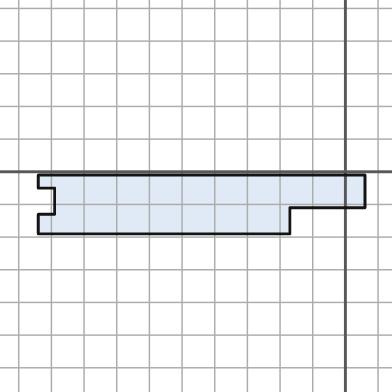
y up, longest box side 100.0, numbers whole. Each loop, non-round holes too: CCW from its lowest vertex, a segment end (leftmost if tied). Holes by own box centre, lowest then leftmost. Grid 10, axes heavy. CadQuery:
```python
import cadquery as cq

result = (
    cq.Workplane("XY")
    .moveTo(-94.0, -19.0)
    .lineTo(-17.0, -19.0)
    .lineTo(-17.0, -11.0)
    .lineTo(6.0, -11.0)
    .lineTo(6.0, -1.0)
    .lineTo(-94.0, -1.0)
    .lineTo(-94.0, -5.0)
    .lineTo(-89.0, -5.0)
    .lineTo(-89.0, -13.0)
    .lineTo(-94.0, -13.0)
    .close()
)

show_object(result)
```